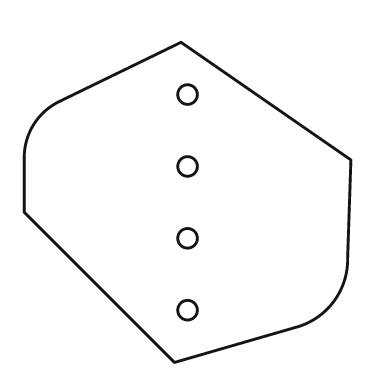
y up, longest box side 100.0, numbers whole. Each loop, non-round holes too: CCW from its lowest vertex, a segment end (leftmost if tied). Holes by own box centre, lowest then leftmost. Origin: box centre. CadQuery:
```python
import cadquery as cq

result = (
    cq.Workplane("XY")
    .moveTo(-4.0, -49.0)
    .lineTo(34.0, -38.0)
    .threePointArc((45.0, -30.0), (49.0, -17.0))
    .lineTo(50.0, 13.0)
    .lineTo(-2.0, 49.0)
    .lineTo(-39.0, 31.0)
    .threePointArc((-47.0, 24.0), (-50.0, 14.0))
    .lineTo(-50.0, -3.0)
    .close()
    .moveTo(0.0, -33.0)
    .circle(3.0)
    .moveTo(0.0, -11.0)
    .circle(3.0)
    .moveTo(0.0, 11.0)
    .circle(3.0)
    .moveTo(0.0, 33.0)
    .circle(3.0)
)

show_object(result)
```